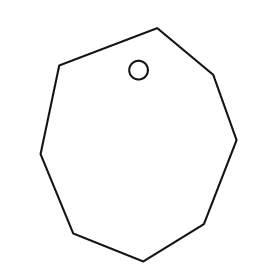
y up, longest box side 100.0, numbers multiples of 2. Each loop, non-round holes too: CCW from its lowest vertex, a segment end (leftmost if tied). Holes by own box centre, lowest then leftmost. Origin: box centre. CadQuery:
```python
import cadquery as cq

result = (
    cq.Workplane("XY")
    .moveTo(2.0, -50.0)
    .lineTo(28.0, -34.0)
    .lineTo(42.0, 2.0)
    .lineTo(32.0, 30.0)
    .lineTo(8.0, 50.0)
    .lineTo(-34.0, 34.0)
    .lineTo(-42.0, -4.0)
    .lineTo(-28.0, -38.0)
    .close()
    .moveTo(0.0, 32.0)
    .circle(4.0)
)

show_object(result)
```